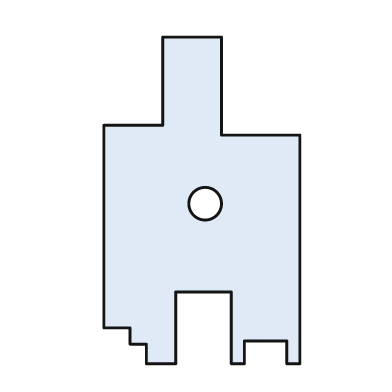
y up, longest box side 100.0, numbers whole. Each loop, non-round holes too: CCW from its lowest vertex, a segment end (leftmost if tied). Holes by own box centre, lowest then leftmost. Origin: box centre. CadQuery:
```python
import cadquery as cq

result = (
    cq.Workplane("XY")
    .moveTo(-17.0, -50.0)
    .lineTo(-8.0, -50.0)
    .lineTo(-8.0, -28.0)
    .lineTo(9.0, -28.0)
    .lineTo(9.0, -50.0)
    .lineTo(13.0, -50.0)
    .lineTo(13.0, -43.0)
    .lineTo(26.0, -43.0)
    .lineTo(26.0, -50.0)
    .lineTo(30.0, -50.0)
    .lineTo(30.0, 20.0)
    .lineTo(6.0, 20.0)
    .lineTo(6.0, 50.0)
    .lineTo(-12.0, 50.0)
    .lineTo(-12.0, 23.0)
    .lineTo(-30.0, 23.0)
    .lineTo(-30.0, -39.0)
    .lineTo(-22.0, -39.0)
    .lineTo(-22.0, -44.0)
    .lineTo(-17.0, -44.0)
    .close()
    .moveTo(1.0, -1.0)
    .circle(5.0)
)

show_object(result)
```